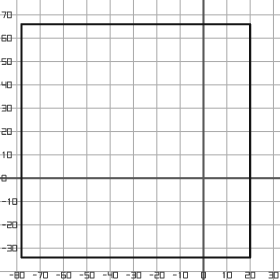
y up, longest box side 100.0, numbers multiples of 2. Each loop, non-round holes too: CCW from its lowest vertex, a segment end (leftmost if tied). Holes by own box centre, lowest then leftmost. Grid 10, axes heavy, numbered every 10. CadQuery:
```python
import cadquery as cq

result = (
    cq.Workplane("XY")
    .moveTo(-78.0, -34.0)
    .lineTo(20.0, -34.0)
    .lineTo(20.0, 66.0)
    .lineTo(-78.0, 66.0)
    .close()
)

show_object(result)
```